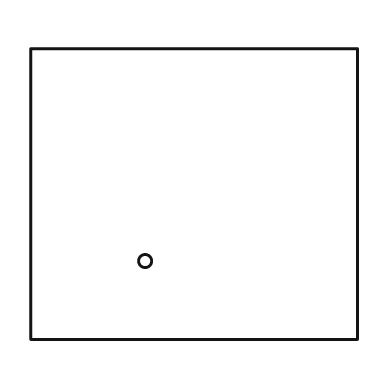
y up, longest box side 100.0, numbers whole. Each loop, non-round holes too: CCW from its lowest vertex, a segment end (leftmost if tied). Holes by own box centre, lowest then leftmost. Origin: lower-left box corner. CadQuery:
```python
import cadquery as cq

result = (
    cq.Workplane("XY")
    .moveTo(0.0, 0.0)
    .lineTo(100.0, 0.0)
    .lineTo(100.0, 89.0)
    .lineTo(0.0, 89.0)
    .close()
    .moveTo(35.0, 24.0)
    .circle(2.0)
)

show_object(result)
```